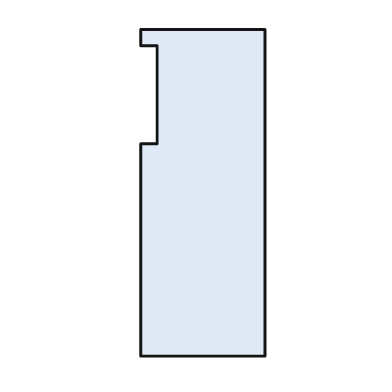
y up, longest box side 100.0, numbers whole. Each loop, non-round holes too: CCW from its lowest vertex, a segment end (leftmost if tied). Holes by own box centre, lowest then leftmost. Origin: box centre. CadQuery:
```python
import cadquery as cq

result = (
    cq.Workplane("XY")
    .moveTo(-19.0, -50.0)
    .lineTo(19.0, -50.0)
    .lineTo(19.0, 50.0)
    .lineTo(-19.0, 50.0)
    .lineTo(-19.0, 45.0)
    .lineTo(-14.0, 45.0)
    .lineTo(-14.0, 15.0)
    .lineTo(-19.0, 15.0)
    .close()
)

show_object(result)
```